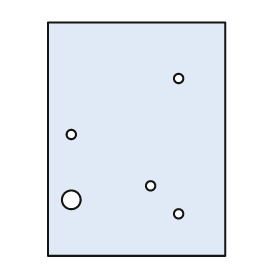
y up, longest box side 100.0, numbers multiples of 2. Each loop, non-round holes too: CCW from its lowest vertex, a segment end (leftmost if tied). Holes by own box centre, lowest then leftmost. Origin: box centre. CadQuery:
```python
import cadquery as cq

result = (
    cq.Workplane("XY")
    .moveTo(-38.0, -50.0)
    .lineTo(38.0, -50.0)
    .lineTo(38.0, 50.0)
    .lineTo(-38.0, 50.0)
    .close()
    .moveTo(18.0, -32.0)
    .circle(2.0)
    .moveTo(-28.0, -26.0)
    .circle(4.0)
    .moveTo(6.0, -20.0)
    .circle(2.0)
    .moveTo(-28.0, 2.0)
    .circle(2.0)
    .moveTo(18.0, 26.0)
    .circle(2.0)
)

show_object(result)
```